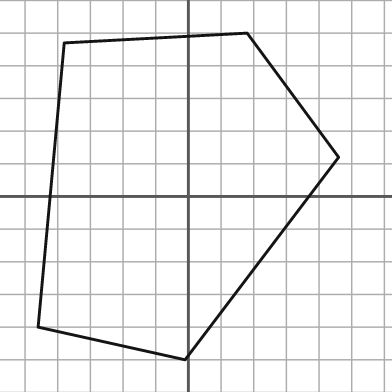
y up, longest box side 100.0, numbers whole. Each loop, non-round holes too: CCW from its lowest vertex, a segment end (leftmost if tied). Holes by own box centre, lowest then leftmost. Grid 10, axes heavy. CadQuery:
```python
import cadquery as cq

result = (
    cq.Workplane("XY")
    .moveTo(-1.0, -50.0)
    .lineTo(46.0, 12.0)
    .lineTo(18.0, 50.0)
    .lineTo(-38.0, 47.0)
    .lineTo(-46.0, -40.0)
    .close()
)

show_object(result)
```